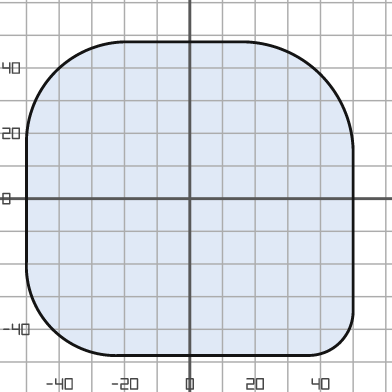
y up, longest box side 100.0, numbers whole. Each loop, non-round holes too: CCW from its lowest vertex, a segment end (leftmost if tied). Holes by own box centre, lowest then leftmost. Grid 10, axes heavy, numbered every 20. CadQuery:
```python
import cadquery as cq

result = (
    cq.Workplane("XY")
    .moveTo(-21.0, -48.0)
    .lineTo(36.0, -48.0)
    .threePointArc((46.0, -44.0), (50.0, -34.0))
    .lineTo(50.0, 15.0)
    .threePointArc((40.0, 38.0), (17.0, 48.0))
    .lineTo(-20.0, 48.0)
    .threePointArc((-41.0, 39.0), (-50.0, 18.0))
    .lineTo(-50.0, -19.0)
    .threePointArc((-42.0, -40.0), (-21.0, -48.0))
    .close()
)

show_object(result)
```